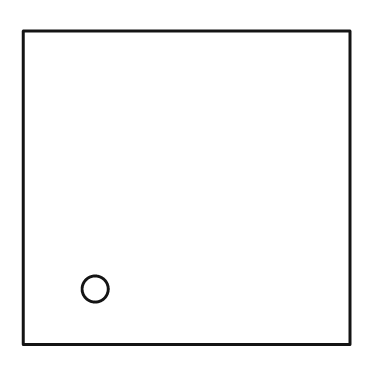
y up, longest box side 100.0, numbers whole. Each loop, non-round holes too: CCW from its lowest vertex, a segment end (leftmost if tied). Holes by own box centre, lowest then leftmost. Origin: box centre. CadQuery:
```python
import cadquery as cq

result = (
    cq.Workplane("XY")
    .moveTo(-50.0, -48.0)
    .lineTo(50.0, -48.0)
    .lineTo(50.0, 48.0)
    .lineTo(-50.0, 48.0)
    .close()
    .moveTo(-28.0, -31.0)
    .circle(4.0)
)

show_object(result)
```